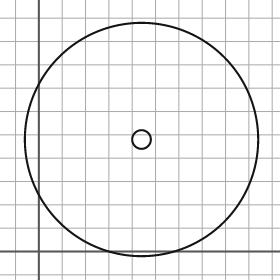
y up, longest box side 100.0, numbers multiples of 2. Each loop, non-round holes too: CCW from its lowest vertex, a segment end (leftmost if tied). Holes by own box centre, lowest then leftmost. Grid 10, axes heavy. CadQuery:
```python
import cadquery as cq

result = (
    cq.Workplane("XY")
    .moveTo(44.0, 48.0)
    .circle(50.0)
    .moveTo(44.0, 48.0)
    .circle(4.0)
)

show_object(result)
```